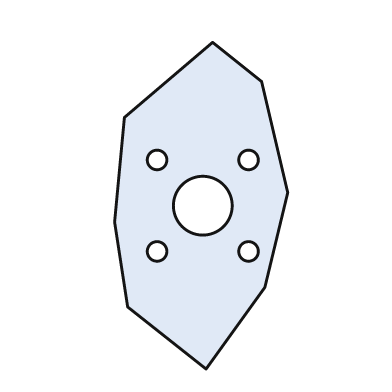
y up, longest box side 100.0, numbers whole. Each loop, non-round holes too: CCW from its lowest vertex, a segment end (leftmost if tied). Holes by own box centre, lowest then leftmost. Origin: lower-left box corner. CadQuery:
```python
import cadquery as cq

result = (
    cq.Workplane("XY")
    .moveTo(28.0, 0.0)
    .lineTo(46.0, 25.0)
    .lineTo(53.0, 54.0)
    .lineTo(45.0, 88.0)
    .lineTo(30.0, 100.0)
    .lineTo(3.0, 77.0)
    .lineTo(0.0, 45.0)
    .lineTo(4.0, 19.0)
    .close()
    .moveTo(13.0, 36.0)
    .circle(3.0)
    .moveTo(41.0, 36.0)
    .circle(3.0)
    .moveTo(27.0, 50.0)
    .circle(9.0)
    .moveTo(13.0, 64.0)
    .circle(3.0)
    .moveTo(41.0, 64.0)
    .circle(3.0)
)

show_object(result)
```